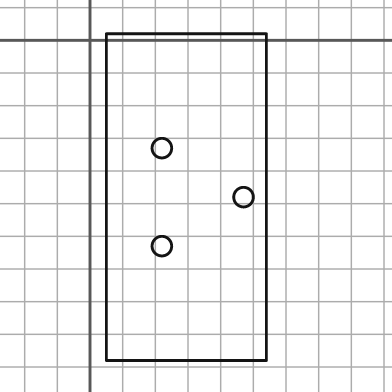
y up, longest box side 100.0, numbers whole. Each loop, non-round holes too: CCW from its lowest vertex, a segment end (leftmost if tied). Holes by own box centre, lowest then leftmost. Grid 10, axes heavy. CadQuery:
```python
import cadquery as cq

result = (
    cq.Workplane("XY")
    .moveTo(5.0, -98.0)
    .lineTo(54.0, -98.0)
    .lineTo(54.0, 2.0)
    .lineTo(5.0, 2.0)
    .close()
    .moveTo(22.0, -63.0)
    .circle(3.0)
    .moveTo(47.0, -48.0)
    .circle(3.0)
    .moveTo(22.0, -33.0)
    .circle(3.0)
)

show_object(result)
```